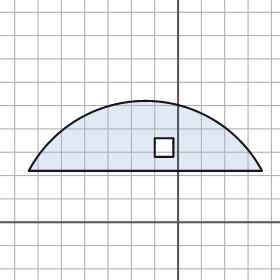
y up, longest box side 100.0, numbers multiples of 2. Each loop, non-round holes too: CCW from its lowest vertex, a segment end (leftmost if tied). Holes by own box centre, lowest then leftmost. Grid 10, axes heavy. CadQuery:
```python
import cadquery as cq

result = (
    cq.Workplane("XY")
    .moveTo(-64.0, 22.0)
    .lineTo(36.0, 22.0)
    .threePointArc((-14.0, 52.0), (-64.0, 22.0))
    .close()
    .moveTo(-10.0, 28.0)
    .lineTo(-2.0, 28.0)
    .lineTo(-2.0, 36.0)
    .lineTo(-10.0, 36.0)
    .close()
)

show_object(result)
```